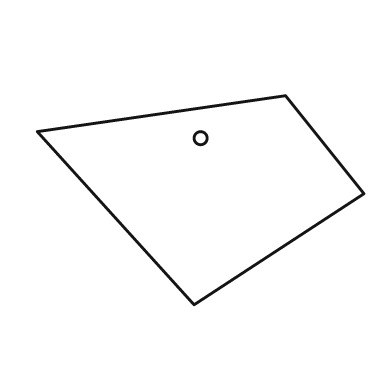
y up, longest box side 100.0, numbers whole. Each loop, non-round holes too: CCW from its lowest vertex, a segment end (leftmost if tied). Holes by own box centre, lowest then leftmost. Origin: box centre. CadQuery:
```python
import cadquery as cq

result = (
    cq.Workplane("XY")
    .moveTo(-2.0, -32.0)
    .lineTo(50.0, 2.0)
    .lineTo(26.0, 32.0)
    .lineTo(-50.0, 21.0)
    .close()
    .moveTo(0.0, 19.0)
    .circle(2.0)
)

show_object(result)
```